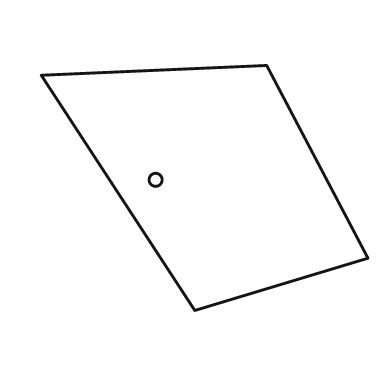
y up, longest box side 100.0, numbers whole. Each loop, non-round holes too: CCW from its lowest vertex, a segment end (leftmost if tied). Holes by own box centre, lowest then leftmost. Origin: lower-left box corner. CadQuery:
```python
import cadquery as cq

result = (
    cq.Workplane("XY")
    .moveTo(47.0, 0.0)
    .lineTo(100.0, 16.0)
    .lineTo(69.0, 75.0)
    .lineTo(0.0, 72.0)
    .close()
    .moveTo(35.0, 40.0)
    .circle(2.0)
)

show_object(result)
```